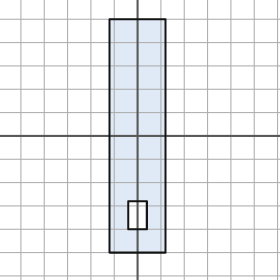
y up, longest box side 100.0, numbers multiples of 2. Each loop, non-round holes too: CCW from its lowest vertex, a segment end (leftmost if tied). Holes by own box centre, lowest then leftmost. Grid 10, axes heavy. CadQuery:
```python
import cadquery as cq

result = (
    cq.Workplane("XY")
    .moveTo(-12.0, -50.0)
    .lineTo(12.0, -50.0)
    .lineTo(12.0, 50.0)
    .lineTo(-12.0, 50.0)
    .close()
    .moveTo(-4.0, -40.0)
    .lineTo(4.0, -40.0)
    .lineTo(4.0, -28.0)
    .lineTo(-4.0, -28.0)
    .close()
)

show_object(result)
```